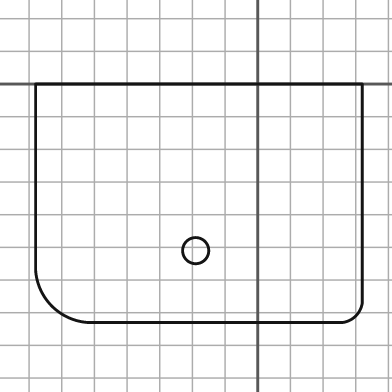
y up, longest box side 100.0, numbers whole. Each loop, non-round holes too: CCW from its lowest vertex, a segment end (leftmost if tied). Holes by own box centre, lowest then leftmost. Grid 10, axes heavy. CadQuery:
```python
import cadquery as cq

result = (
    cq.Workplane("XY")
    .moveTo(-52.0, -73.0)
    .lineTo(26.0, -73.0)
    .threePointArc((30.0, -71.0), (32.0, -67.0))
    .lineTo(32.0, 0.0)
    .lineTo(-68.0, 0.0)
    .lineTo(-68.0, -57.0)
    .threePointArc((-63.0, -68.0), (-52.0, -73.0))
    .close()
    .moveTo(-19.0, -51.0)
    .circle(4.0)
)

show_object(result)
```